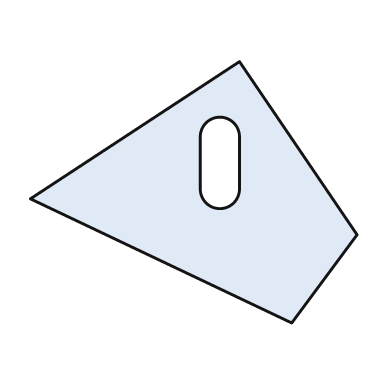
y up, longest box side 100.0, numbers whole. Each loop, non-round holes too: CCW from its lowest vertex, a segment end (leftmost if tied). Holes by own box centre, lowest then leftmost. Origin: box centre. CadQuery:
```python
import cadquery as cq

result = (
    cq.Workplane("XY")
    .moveTo(30.0, -40.0)
    .lineTo(50.0, -13.0)
    .lineTo(14.0, 40.0)
    .lineTo(-50.0, -2.0)
    .close()
    .moveTo(2.0, 1.0)
    .threePointArc((8.0, -5.0), (14.0, 1.0))
    .lineTo(14.0, 17.0)
    .threePointArc((8.0, 23.0), (2.0, 17.0))
    .close()
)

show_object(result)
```